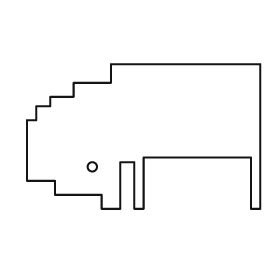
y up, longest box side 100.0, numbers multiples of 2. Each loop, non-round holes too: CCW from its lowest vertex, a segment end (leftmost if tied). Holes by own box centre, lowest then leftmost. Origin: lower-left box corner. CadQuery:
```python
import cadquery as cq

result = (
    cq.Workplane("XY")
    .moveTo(32.0, 0.0)
    .lineTo(40.0, 0.0)
    .lineTo(40.0, 20.0)
    .lineTo(46.0, 20.0)
    .lineTo(46.0, 0.0)
    .lineTo(50.0, 0.0)
    .lineTo(50.0, 22.0)
    .lineTo(96.0, 22.0)
    .lineTo(96.0, 0.0)
    .lineTo(100.0, 0.0)
    .lineTo(100.0, 62.0)
    .lineTo(36.0, 62.0)
    .lineTo(36.0, 54.0)
    .lineTo(20.0, 54.0)
    .lineTo(20.0, 48.0)
    .lineTo(10.0, 48.0)
    .lineTo(10.0, 44.0)
    .lineTo(4.0, 44.0)
    .lineTo(4.0, 38.0)
    .lineTo(0.0, 38.0)
    .lineTo(0.0, 12.0)
    .lineTo(12.0, 12.0)
    .lineTo(12.0, 6.0)
    .lineTo(32.0, 6.0)
    .close()
    .moveTo(28.0, 18.0)
    .circle(2.0)
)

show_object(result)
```